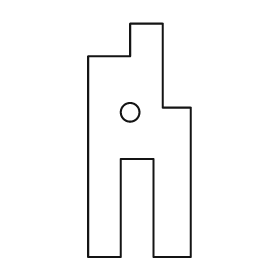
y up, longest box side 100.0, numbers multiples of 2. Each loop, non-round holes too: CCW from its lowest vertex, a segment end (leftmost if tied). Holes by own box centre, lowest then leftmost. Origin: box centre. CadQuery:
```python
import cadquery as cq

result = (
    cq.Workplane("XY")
    .moveTo(-22.0, -50.0)
    .lineTo(-8.0, -50.0)
    .lineTo(-8.0, -8.0)
    .lineTo(6.0, -8.0)
    .lineTo(6.0, -50.0)
    .lineTo(22.0, -50.0)
    .lineTo(22.0, 14.0)
    .lineTo(10.0, 14.0)
    .lineTo(10.0, 50.0)
    .lineTo(-4.0, 50.0)
    .lineTo(-4.0, 36.0)
    .lineTo(-22.0, 36.0)
    .close()
    .moveTo(-4.0, 12.0)
    .circle(4.0)
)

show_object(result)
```